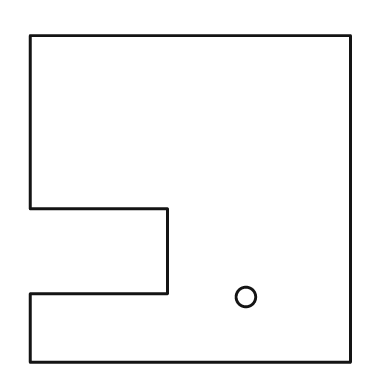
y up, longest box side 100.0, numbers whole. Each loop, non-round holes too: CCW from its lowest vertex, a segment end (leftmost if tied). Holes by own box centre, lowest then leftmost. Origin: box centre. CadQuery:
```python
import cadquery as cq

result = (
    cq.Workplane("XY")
    .moveTo(-49.0, -50.0)
    .lineTo(49.0, -50.0)
    .lineTo(49.0, 50.0)
    .lineTo(-49.0, 50.0)
    .lineTo(-49.0, -3.0)
    .lineTo(-7.0, -3.0)
    .lineTo(-7.0, -29.0)
    .lineTo(-49.0, -29.0)
    .close()
    .moveTo(17.0, -30.0)
    .circle(3.0)
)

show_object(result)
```